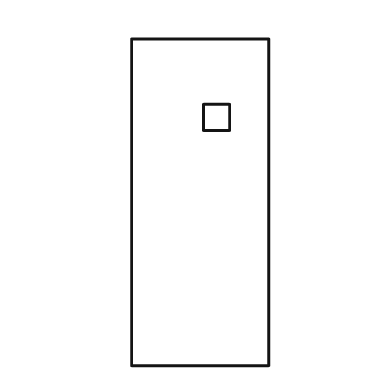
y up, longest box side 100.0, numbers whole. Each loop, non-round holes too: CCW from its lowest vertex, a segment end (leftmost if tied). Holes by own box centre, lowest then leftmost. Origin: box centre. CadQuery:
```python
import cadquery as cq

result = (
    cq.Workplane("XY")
    .moveTo(-21.0, -50.0)
    .lineTo(21.0, -50.0)
    .lineTo(21.0, 50.0)
    .lineTo(-21.0, 50.0)
    .close()
    .moveTo(1.0, 22.0)
    .lineTo(9.0, 22.0)
    .lineTo(9.0, 30.0)
    .lineTo(1.0, 30.0)
    .close()
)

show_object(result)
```